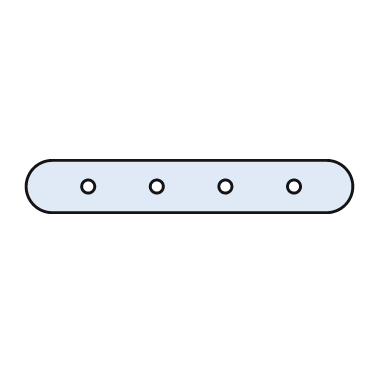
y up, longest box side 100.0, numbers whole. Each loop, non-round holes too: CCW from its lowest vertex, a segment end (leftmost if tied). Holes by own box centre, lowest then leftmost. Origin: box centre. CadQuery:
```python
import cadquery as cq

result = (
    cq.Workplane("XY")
    .moveTo(-42.0, -8.0)
    .lineTo(42.0, -8.0)
    .threePointArc((50.0, 0.0), (42.0, 8.0))
    .lineTo(-42.0, 8.0)
    .threePointArc((-50.0, 0.0), (-42.0, -8.0))
    .close()
    .moveTo(-31.0, 0.0)
    .circle(2.0)
    .moveTo(-10.0, 0.0)
    .circle(2.0)
    .moveTo(11.0, 0.0)
    .circle(2.0)
    .moveTo(32.0, 0.0)
    .circle(2.0)
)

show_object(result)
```